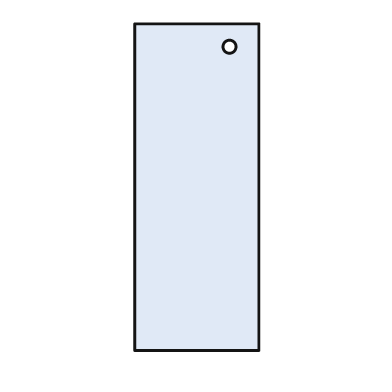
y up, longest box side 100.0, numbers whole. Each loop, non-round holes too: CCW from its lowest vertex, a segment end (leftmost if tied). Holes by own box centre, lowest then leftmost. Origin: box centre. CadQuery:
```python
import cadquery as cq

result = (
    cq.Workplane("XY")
    .moveTo(-19.0, -50.0)
    .lineTo(19.0, -50.0)
    .lineTo(19.0, 50.0)
    .lineTo(-19.0, 50.0)
    .close()
    .moveTo(10.0, 43.0)
    .circle(2.0)
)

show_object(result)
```